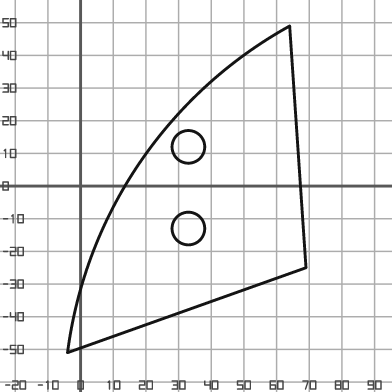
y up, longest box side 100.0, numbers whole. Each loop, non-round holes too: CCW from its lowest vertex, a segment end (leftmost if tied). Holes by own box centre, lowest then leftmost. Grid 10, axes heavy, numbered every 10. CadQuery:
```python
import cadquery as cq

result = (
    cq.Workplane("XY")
    .moveTo(-4.0, -51.0)
    .lineTo(69.0, -25.0)
    .lineTo(64.0, 49.0)
    .threePointArc((18.0, 7.0), (-4.0, -51.0))
    .close()
    .moveTo(33.0, -13.0)
    .circle(5.0)
    .moveTo(33.0, 12.0)
    .circle(5.0)
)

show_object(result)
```